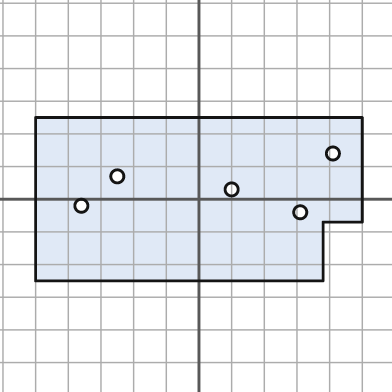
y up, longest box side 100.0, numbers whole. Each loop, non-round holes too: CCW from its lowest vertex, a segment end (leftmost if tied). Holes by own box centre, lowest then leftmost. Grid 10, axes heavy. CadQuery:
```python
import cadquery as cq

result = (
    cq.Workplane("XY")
    .moveTo(-50.0, -25.0)
    .lineTo(38.0, -25.0)
    .lineTo(38.0, -7.0)
    .lineTo(50.0, -7.0)
    .lineTo(50.0, 25.0)
    .lineTo(-50.0, 25.0)
    .close()
    .moveTo(31.0, -4.0)
    .circle(2.0)
    .moveTo(-36.0, -2.0)
    .circle(2.0)
    .moveTo(10.0, 3.0)
    .circle(2.0)
    .moveTo(-25.0, 7.0)
    .circle(2.0)
    .moveTo(41.0, 14.0)
    .circle(2.0)
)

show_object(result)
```